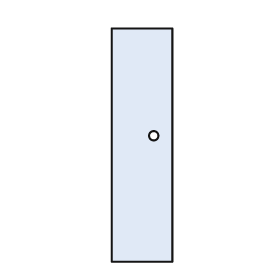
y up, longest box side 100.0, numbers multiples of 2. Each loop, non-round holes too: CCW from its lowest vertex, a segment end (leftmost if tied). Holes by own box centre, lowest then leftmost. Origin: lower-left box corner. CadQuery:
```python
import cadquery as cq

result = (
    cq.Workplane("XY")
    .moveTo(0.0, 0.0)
    .lineTo(26.0, 0.0)
    .lineTo(26.0, 100.0)
    .lineTo(0.0, 100.0)
    .close()
    .moveTo(18.0, 54.0)
    .circle(2.0)
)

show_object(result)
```